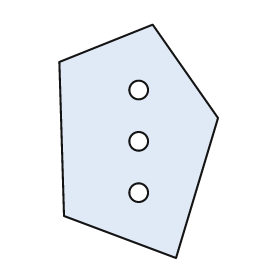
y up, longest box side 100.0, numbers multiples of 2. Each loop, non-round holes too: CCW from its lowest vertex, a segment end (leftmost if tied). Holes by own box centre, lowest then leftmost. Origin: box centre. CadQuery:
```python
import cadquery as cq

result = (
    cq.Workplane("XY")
    .moveTo(16.0, -50.0)
    .lineTo(34.0, 10.0)
    .lineTo(6.0, 50.0)
    .lineTo(-34.0, 34.0)
    .lineTo(-32.0, -32.0)
    .close()
    .moveTo(0.0, -22.0)
    .circle(4.0)
    .moveTo(0.0, 0.0)
    .circle(4.0)
    .moveTo(0.0, 22.0)
    .circle(4.0)
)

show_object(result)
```